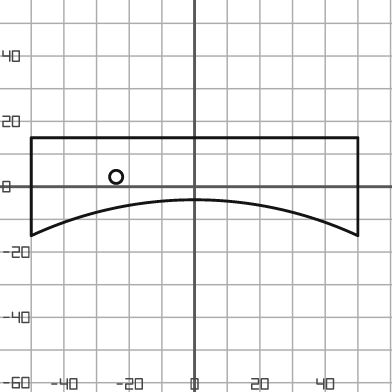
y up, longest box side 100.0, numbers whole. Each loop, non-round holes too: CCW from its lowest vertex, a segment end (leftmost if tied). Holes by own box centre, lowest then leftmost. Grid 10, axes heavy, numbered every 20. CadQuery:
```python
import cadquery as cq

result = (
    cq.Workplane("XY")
    .moveTo(-50.0, -15.0)
    .threePointArc((0.0, -4.0), (50.0, -15.0))
    .lineTo(50.0, 15.0)
    .lineTo(-50.0, 15.0)
    .close()
    .moveTo(-24.0, 3.0)
    .circle(2.0)
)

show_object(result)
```